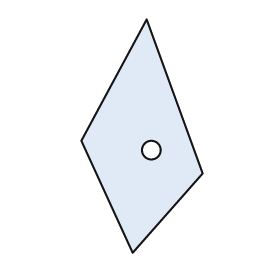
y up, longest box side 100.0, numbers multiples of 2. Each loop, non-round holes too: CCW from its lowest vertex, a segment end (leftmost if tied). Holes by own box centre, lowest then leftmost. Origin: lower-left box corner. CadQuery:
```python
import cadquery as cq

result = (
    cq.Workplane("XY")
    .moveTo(22.0, 0.0)
    .lineTo(52.0, 34.0)
    .lineTo(28.0, 100.0)
    .lineTo(0.0, 48.0)
    .close()
    .moveTo(30.0, 44.0)
    .circle(4.0)
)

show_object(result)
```